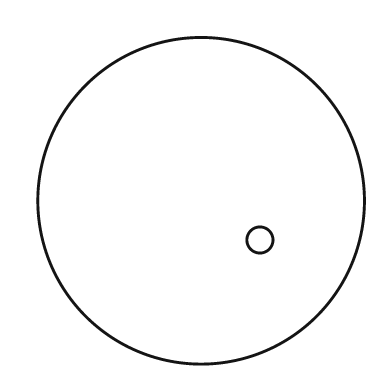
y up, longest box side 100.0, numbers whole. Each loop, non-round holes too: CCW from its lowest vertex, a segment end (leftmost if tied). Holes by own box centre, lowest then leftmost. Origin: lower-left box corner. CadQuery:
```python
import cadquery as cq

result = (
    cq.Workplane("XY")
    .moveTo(50.0, 50.0)
    .circle(50.0)
    .moveTo(68.0, 38.0)
    .circle(4.0)
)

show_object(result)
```